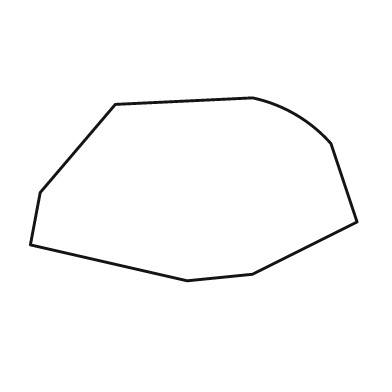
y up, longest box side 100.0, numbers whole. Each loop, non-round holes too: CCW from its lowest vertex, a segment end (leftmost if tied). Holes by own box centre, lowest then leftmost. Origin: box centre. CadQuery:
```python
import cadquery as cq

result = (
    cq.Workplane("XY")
    .moveTo(-2.0, -28.0)
    .lineTo(18.0, -26.0)
    .lineTo(50.0, -10.0)
    .lineTo(42.0, 14.0)
    .threePointArc((31.0, 23.0), (18.0, 28.0))
    .lineTo(-24.0, 26.0)
    .lineTo(-47.0, -1.0)
    .lineTo(-50.0, -17.0)
    .close()
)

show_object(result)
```